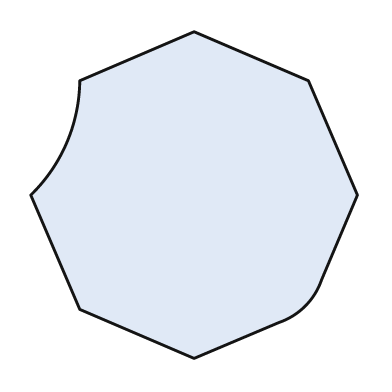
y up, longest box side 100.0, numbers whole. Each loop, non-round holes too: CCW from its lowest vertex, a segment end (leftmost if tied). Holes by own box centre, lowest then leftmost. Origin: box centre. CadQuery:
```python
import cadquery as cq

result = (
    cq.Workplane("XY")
    .moveTo(0.0, -50.0)
    .lineTo(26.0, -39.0)
    .threePointArc((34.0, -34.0), (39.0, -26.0))
    .lineTo(50.0, 0.0)
    .lineTo(35.0, 35.0)
    .lineTo(0.0, 50.0)
    .lineTo(-35.0, 35.0)
    .threePointArc((-39.0, 16.0), (-50.0, 0.0))
    .lineTo(-35.0, -35.0)
    .close()
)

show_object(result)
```